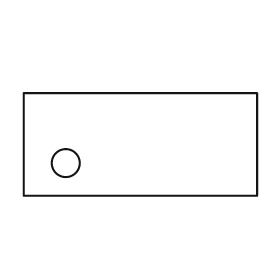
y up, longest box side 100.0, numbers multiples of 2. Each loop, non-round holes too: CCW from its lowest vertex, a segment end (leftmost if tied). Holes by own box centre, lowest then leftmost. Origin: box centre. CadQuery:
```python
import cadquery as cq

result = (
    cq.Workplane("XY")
    .moveTo(-50.0, -22.0)
    .lineTo(50.0, -22.0)
    .lineTo(50.0, 22.0)
    .lineTo(-50.0, 22.0)
    .close()
    .moveTo(-32.0, -8.0)
    .circle(6.0)
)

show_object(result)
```